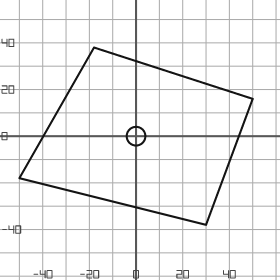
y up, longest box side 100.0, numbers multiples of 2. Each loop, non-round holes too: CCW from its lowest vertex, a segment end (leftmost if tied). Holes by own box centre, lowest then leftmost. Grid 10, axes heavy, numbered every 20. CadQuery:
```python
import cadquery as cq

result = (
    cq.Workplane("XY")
    .moveTo(30.0, -38.0)
    .lineTo(50.0, 16.0)
    .lineTo(-18.0, 38.0)
    .lineTo(-50.0, -18.0)
    .close()
    .moveTo(0.0, 0.0)
    .circle(4.0)
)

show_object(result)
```